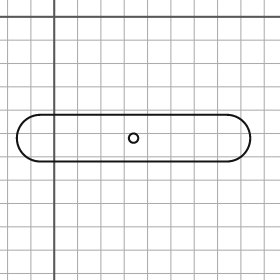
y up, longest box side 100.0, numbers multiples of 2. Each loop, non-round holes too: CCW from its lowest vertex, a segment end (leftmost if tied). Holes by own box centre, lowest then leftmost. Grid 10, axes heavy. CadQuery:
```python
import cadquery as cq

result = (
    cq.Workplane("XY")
    .moveTo(-6.0, -62.0)
    .lineTo(74.0, -62.0)
    .threePointArc((84.0, -52.0), (74.0, -42.0))
    .lineTo(-6.0, -42.0)
    .threePointArc((-16.0, -52.0), (-6.0, -62.0))
    .close()
    .moveTo(34.0, -52.0)
    .circle(2.0)
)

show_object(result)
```